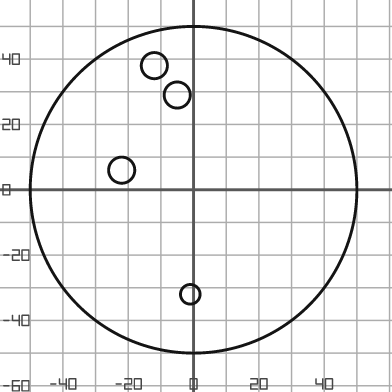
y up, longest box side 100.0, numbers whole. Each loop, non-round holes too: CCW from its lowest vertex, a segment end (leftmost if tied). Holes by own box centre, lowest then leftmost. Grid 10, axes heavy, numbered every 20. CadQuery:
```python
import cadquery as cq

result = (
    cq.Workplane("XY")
    .moveTo(0.0, 0.0)
    .circle(50.0)
    .moveTo(-1.0, -32.0)
    .circle(3.0)
    .moveTo(-22.0, 6.0)
    .circle(4.0)
    .moveTo(-5.0, 29.0)
    .circle(4.0)
    .moveTo(-12.0, 38.0)
    .circle(4.0)
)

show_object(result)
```